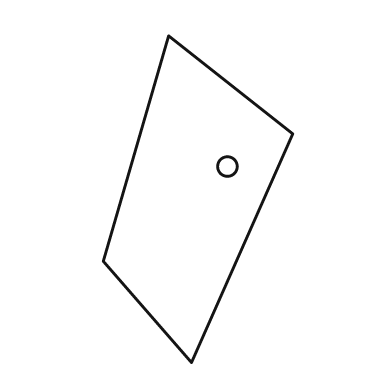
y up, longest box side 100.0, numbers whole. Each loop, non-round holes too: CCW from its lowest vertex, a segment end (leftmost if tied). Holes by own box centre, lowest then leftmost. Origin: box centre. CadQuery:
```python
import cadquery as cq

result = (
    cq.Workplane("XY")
    .moveTo(-2.0, -50.0)
    .lineTo(29.0, 20.0)
    .lineTo(-9.0, 50.0)
    .lineTo(-29.0, -19.0)
    .close()
    .moveTo(9.0, 10.0)
    .circle(3.0)
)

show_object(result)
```